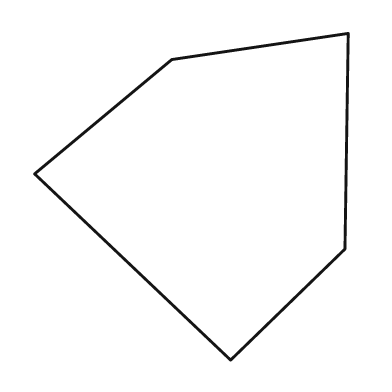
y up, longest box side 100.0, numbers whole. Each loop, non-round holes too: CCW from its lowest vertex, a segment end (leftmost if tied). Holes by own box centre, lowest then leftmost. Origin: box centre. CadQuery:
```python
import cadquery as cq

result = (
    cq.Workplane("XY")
    .moveTo(12.0, -50.0)
    .lineTo(47.0, -16.0)
    .lineTo(48.0, 50.0)
    .lineTo(-6.0, 42.0)
    .lineTo(-48.0, 7.0)
    .close()
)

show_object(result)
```